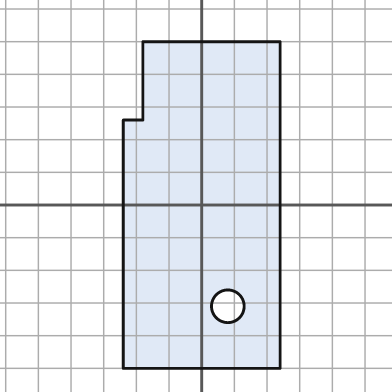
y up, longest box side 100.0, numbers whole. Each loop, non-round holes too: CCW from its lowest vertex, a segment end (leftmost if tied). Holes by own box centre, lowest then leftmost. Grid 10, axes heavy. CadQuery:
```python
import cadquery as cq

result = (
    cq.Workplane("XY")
    .moveTo(-24.0, -50.0)
    .lineTo(24.0, -50.0)
    .lineTo(24.0, 50.0)
    .lineTo(-18.0, 50.0)
    .lineTo(-18.0, 26.0)
    .lineTo(-24.0, 26.0)
    .close()
    .moveTo(8.0, -31.0)
    .circle(5.0)
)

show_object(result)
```